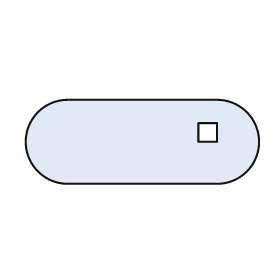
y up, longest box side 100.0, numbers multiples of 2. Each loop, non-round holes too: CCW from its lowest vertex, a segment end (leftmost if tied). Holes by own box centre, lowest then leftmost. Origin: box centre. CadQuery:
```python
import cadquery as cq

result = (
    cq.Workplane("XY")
    .moveTo(-32.0, -18.0)
    .lineTo(32.0, -18.0)
    .threePointArc((50.0, 0.0), (32.0, 18.0))
    .lineTo(-32.0, 18.0)
    .threePointArc((-50.0, 0.0), (-32.0, -18.0))
    .close()
    .moveTo(24.0, 0.0)
    .lineTo(32.0, 0.0)
    .lineTo(32.0, 8.0)
    .lineTo(24.0, 8.0)
    .close()
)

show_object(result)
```